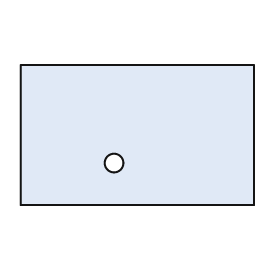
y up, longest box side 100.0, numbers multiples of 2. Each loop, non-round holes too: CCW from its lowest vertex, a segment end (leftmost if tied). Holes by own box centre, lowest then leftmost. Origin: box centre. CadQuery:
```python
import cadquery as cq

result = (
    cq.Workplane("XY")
    .moveTo(-50.0, -30.0)
    .lineTo(50.0, -30.0)
    .lineTo(50.0, 30.0)
    .lineTo(-50.0, 30.0)
    .close()
    .moveTo(-10.0, -12.0)
    .circle(4.0)
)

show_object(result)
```